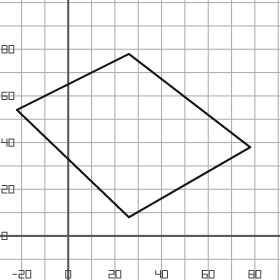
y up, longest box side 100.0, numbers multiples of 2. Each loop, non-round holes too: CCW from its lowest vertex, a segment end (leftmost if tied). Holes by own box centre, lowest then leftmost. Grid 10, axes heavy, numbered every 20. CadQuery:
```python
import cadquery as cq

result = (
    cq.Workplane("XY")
    .moveTo(26.0, 8.0)
    .lineTo(78.0, 38.0)
    .lineTo(26.0, 78.0)
    .lineTo(-22.0, 54.0)
    .close()
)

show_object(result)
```